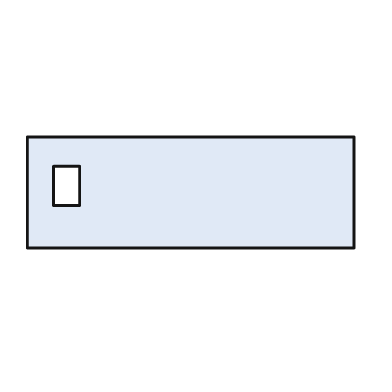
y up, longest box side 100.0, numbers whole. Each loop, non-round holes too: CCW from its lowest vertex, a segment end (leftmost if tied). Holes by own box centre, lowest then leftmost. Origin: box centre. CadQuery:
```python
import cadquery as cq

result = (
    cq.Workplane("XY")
    .moveTo(-50.0, -17.0)
    .lineTo(50.0, -17.0)
    .lineTo(50.0, 17.0)
    .lineTo(-50.0, 17.0)
    .close()
    .moveTo(-42.0, -4.0)
    .lineTo(-34.0, -4.0)
    .lineTo(-34.0, 8.0)
    .lineTo(-42.0, 8.0)
    .close()
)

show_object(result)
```